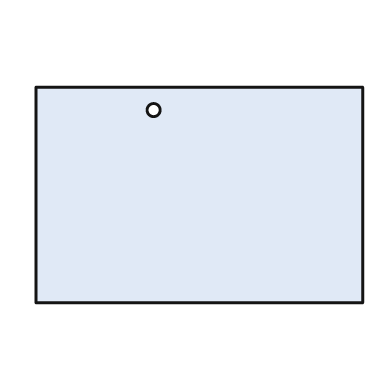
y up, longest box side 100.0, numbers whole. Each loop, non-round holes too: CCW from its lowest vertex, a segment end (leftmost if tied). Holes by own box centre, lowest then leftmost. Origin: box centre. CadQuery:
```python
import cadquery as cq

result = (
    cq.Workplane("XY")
    .moveTo(-50.0, -33.0)
    .lineTo(50.0, -33.0)
    .lineTo(50.0, 33.0)
    .lineTo(-50.0, 33.0)
    .close()
    .moveTo(-14.0, 26.0)
    .circle(2.0)
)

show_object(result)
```